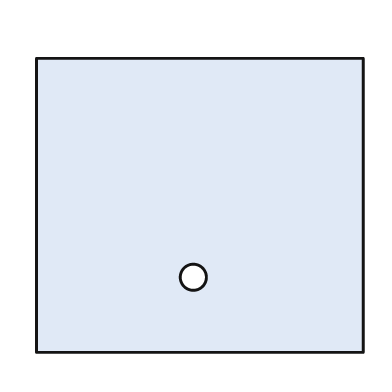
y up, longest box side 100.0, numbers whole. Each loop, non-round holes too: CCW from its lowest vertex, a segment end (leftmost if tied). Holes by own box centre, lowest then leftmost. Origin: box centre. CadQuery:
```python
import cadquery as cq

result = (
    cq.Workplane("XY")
    .moveTo(-50.0, -45.0)
    .lineTo(50.0, -45.0)
    .lineTo(50.0, 45.0)
    .lineTo(-50.0, 45.0)
    .close()
    .moveTo(-2.0, -22.0)
    .circle(4.0)
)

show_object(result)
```